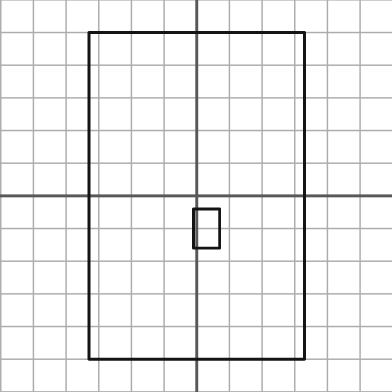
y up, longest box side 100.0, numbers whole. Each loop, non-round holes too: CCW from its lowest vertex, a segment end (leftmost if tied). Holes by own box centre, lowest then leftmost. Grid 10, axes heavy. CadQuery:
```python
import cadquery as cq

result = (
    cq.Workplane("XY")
    .moveTo(-33.0, -50.0)
    .lineTo(33.0, -50.0)
    .lineTo(33.0, 50.0)
    .lineTo(-33.0, 50.0)
    .close()
    .moveTo(-1.0, -16.0)
    .lineTo(7.0, -16.0)
    .lineTo(7.0, -4.0)
    .lineTo(-1.0, -4.0)
    .close()
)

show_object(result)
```